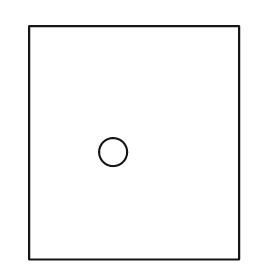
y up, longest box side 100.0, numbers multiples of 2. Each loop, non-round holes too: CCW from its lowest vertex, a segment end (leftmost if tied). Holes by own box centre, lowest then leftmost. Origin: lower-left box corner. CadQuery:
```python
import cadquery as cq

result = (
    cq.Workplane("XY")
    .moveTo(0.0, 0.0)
    .lineTo(90.0, 0.0)
    .lineTo(90.0, 100.0)
    .lineTo(0.0, 100.0)
    .close()
    .moveTo(36.0, 46.0)
    .circle(6.0)
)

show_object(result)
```